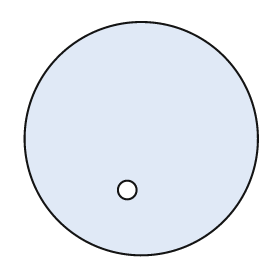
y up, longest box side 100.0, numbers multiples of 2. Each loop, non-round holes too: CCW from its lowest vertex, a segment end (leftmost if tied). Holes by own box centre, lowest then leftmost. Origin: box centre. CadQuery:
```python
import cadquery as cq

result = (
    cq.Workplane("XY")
    .moveTo(0.0, 0.0)
    .circle(50.0)
    .moveTo(-6.0, -22.0)
    .circle(4.0)
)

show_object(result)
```